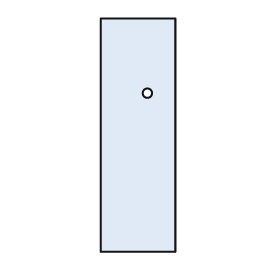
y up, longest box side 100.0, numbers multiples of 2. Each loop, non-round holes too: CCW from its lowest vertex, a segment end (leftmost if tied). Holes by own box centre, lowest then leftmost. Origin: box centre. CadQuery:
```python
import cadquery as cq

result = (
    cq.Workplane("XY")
    .moveTo(-16.0, -50.0)
    .lineTo(16.0, -50.0)
    .lineTo(16.0, 50.0)
    .lineTo(-16.0, 50.0)
    .close()
    .moveTo(4.0, 18.0)
    .circle(2.0)
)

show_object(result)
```